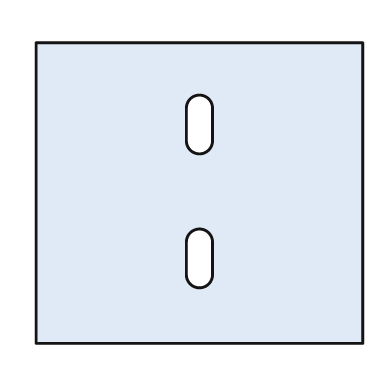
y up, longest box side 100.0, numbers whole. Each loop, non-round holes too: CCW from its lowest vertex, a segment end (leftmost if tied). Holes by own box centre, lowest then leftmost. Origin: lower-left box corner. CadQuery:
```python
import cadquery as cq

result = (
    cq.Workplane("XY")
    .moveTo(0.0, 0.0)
    .lineTo(100.0, 0.0)
    .lineTo(100.0, 92.0)
    .lineTo(0.0, 92.0)
    .close()
    .moveTo(46.0, 21.0)
    .threePointArc((50.0, 17.0), (54.0, 21.0))
    .lineTo(54.0, 31.0)
    .threePointArc((50.0, 35.0), (46.0, 31.0))
    .close()
    .moveTo(46.0, 62.0)
    .threePointArc((50.0, 58.0), (54.0, 62.0))
    .lineTo(54.0, 72.0)
    .threePointArc((50.0, 76.0), (46.0, 72.0))
    .close()
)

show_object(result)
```